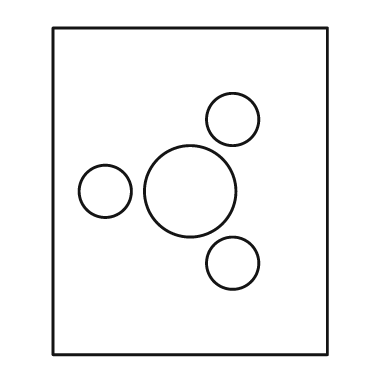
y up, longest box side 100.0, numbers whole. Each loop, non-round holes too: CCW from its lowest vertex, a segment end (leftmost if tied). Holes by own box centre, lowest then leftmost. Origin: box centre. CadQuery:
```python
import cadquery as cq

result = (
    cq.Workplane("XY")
    .moveTo(-42.0, -50.0)
    .lineTo(42.0, -50.0)
    .lineTo(42.0, 50.0)
    .lineTo(-42.0, 50.0)
    .close()
    .moveTo(13.0, -22.0)
    .circle(8.0)
    .moveTo(-26.0, 0.0)
    .circle(8.0)
    .moveTo(0.0, 0.0)
    .circle(14.0)
    .moveTo(13.0, 22.0)
    .circle(8.0)
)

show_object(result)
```